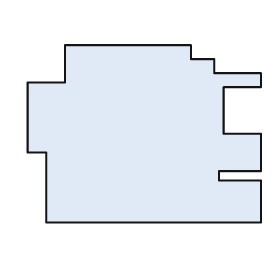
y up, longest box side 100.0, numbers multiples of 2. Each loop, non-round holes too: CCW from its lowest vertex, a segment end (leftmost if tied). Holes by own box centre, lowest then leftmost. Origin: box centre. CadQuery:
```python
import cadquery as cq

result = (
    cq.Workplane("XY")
    .moveTo(-42.0, -38.0)
    .lineTo(50.0, -38.0)
    .lineTo(50.0, -20.0)
    .lineTo(32.0, -20.0)
    .lineTo(32.0, -16.0)
    .lineTo(50.0, -16.0)
    .lineTo(50.0, 0.0)
    .lineTo(34.0, 0.0)
    .lineTo(34.0, 20.0)
    .lineTo(50.0, 20.0)
    .lineTo(50.0, 26.0)
    .lineTo(30.0, 26.0)
    .lineTo(30.0, 32.0)
    .lineTo(20.0, 32.0)
    .lineTo(20.0, 38.0)
    .lineTo(-34.0, 38.0)
    .lineTo(-34.0, 22.0)
    .lineTo(-50.0, 22.0)
    .lineTo(-50.0, -8.0)
    .lineTo(-42.0, -8.0)
    .close()
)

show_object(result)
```